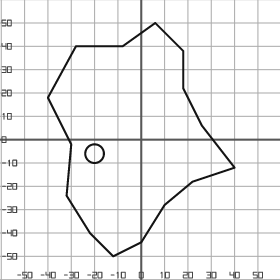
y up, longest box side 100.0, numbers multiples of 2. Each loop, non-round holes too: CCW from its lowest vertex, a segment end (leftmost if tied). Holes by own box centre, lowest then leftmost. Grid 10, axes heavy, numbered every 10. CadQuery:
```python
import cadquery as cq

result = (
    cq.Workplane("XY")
    .moveTo(-12.0, -50.0)
    .lineTo(0.0, -44.0)
    .lineTo(10.0, -28.0)
    .lineTo(22.0, -18.0)
    .lineTo(40.0, -12.0)
    .lineTo(26.0, 6.0)
    .lineTo(18.0, 22.0)
    .lineTo(18.0, 38.0)
    .lineTo(6.0, 50.0)
    .lineTo(-8.0, 40.0)
    .lineTo(-28.0, 40.0)
    .lineTo(-40.0, 18.0)
    .lineTo(-30.0, -2.0)
    .lineTo(-32.0, -24.0)
    .lineTo(-22.0, -40.0)
    .close()
    .moveTo(-20.0, -6.0)
    .circle(4.0)
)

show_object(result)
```